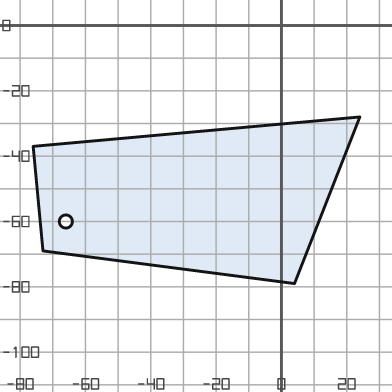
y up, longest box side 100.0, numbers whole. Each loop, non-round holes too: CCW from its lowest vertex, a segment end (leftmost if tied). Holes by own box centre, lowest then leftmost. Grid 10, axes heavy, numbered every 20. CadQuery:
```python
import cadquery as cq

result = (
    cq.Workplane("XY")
    .moveTo(4.0, -79.0)
    .lineTo(24.0, -28.0)
    .lineTo(-76.0, -37.0)
    .lineTo(-73.0, -69.0)
    .close()
    .moveTo(-66.0, -60.0)
    .circle(2.0)
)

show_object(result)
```